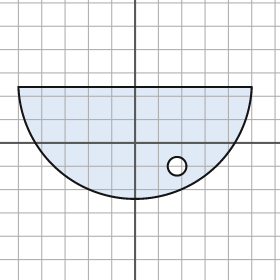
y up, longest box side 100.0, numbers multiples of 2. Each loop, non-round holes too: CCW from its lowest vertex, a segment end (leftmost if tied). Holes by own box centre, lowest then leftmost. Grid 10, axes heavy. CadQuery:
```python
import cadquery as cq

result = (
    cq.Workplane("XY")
    .moveTo(-50.0, 24.0)
    .threePointArc((0.0, -24.0), (50.0, 24.0))
    .close()
    .moveTo(18.0, -10.0)
    .circle(4.0)
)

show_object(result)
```